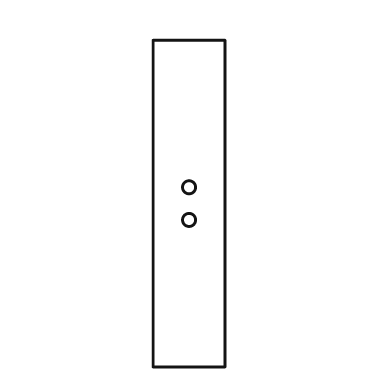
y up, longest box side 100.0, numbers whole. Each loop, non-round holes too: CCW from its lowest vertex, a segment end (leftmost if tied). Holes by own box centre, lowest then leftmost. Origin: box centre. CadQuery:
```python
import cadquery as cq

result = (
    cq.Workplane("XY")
    .moveTo(-11.0, -50.0)
    .lineTo(11.0, -50.0)
    .lineTo(11.0, 50.0)
    .lineTo(-11.0, 50.0)
    .close()
    .moveTo(0.0, -5.0)
    .circle(2.0)
    .moveTo(0.0, 5.0)
    .circle(2.0)
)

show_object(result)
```